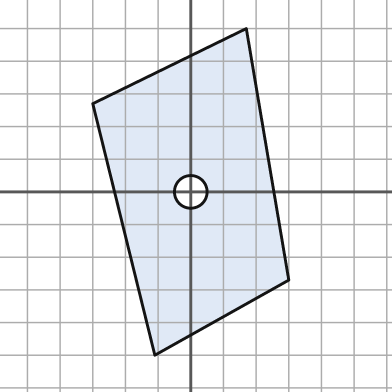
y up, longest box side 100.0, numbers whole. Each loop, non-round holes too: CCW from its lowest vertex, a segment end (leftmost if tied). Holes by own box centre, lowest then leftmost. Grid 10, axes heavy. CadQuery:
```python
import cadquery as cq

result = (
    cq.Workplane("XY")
    .moveTo(-11.0, -50.0)
    .lineTo(30.0, -27.0)
    .lineTo(17.0, 50.0)
    .lineTo(-30.0, 27.0)
    .close()
    .moveTo(0.0, 0.0)
    .circle(5.0)
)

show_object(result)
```